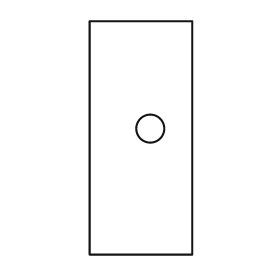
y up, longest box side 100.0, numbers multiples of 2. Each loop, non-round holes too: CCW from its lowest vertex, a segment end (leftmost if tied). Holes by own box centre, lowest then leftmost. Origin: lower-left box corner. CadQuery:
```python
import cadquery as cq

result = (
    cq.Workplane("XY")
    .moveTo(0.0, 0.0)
    .lineTo(44.0, 0.0)
    .lineTo(44.0, 100.0)
    .lineTo(0.0, 100.0)
    .close()
    .moveTo(26.0, 54.0)
    .circle(6.0)
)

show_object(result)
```